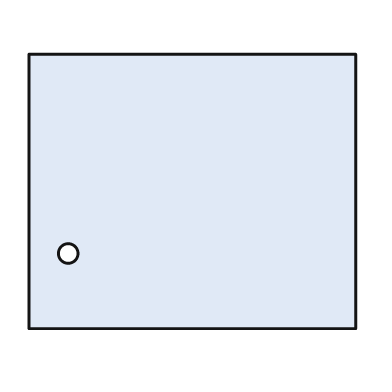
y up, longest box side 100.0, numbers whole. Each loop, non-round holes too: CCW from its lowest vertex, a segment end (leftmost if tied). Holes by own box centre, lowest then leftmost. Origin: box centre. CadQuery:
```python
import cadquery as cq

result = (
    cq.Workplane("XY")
    .moveTo(-50.0, -42.0)
    .lineTo(50.0, -42.0)
    .lineTo(50.0, 42.0)
    .lineTo(-50.0, 42.0)
    .close()
    .moveTo(-38.0, -19.0)
    .circle(3.0)
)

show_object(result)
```